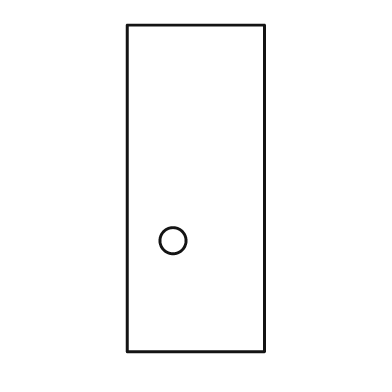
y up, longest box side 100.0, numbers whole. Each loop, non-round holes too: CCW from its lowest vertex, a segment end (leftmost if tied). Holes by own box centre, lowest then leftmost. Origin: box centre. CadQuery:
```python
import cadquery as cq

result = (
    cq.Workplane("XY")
    .moveTo(-21.0, -50.0)
    .lineTo(21.0, -50.0)
    .lineTo(21.0, 50.0)
    .lineTo(-21.0, 50.0)
    .close()
    .moveTo(-7.0, -16.0)
    .circle(4.0)
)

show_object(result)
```